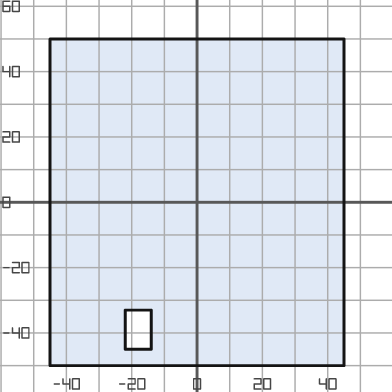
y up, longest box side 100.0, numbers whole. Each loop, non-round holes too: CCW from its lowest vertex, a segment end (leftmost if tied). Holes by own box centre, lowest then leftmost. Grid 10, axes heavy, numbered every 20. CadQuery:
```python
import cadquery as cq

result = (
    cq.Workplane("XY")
    .moveTo(-45.0, -50.0)
    .lineTo(45.0, -50.0)
    .lineTo(45.0, 50.0)
    .lineTo(-45.0, 50.0)
    .close()
    .moveTo(-22.0, -45.0)
    .lineTo(-14.0, -45.0)
    .lineTo(-14.0, -33.0)
    .lineTo(-22.0, -33.0)
    .close()
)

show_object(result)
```